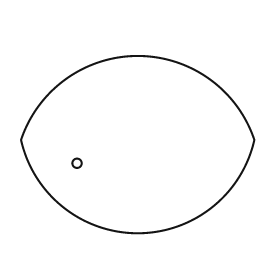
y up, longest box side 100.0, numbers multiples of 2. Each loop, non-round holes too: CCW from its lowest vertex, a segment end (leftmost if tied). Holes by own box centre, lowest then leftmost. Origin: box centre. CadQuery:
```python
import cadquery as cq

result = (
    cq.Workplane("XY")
    .moveTo(-50.0, 2.0)
    .threePointArc((0.0, -38.0), (50.0, 2.0))
    .threePointArc((0.0, 38.0), (-50.0, 2.0))
    .close()
    .moveTo(-26.0, -8.0)
    .circle(2.0)
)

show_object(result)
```